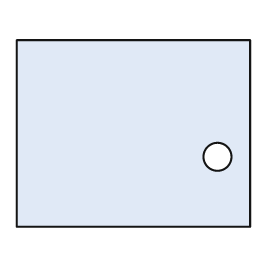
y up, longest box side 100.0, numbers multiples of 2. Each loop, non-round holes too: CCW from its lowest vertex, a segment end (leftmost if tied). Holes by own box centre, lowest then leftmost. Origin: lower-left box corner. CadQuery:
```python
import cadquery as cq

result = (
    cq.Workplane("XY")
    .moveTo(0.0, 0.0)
    .lineTo(100.0, 0.0)
    .lineTo(100.0, 80.0)
    .lineTo(0.0, 80.0)
    .close()
    .moveTo(86.0, 30.0)
    .circle(6.0)
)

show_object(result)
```